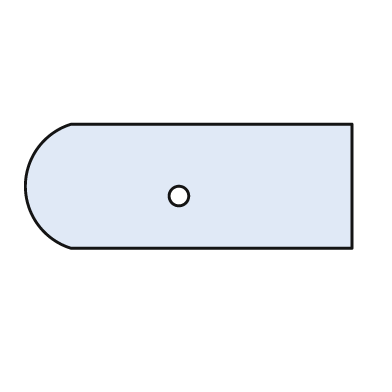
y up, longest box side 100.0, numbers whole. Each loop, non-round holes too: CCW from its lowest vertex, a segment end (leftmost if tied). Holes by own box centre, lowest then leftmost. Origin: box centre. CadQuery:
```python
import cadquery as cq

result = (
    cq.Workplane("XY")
    .moveTo(-36.0, -19.0)
    .lineTo(50.0, -19.0)
    .lineTo(50.0, 19.0)
    .lineTo(-36.0, 19.0)
    .threePointArc((-50.0, 0.0), (-36.0, -19.0))
    .close()
    .moveTo(-3.0, -3.0)
    .circle(3.0)
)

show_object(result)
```